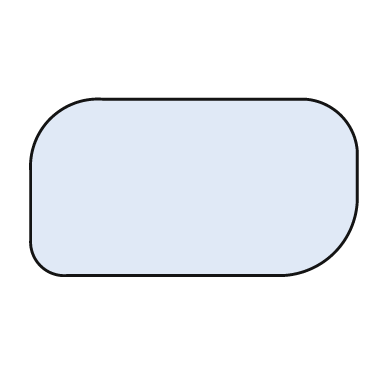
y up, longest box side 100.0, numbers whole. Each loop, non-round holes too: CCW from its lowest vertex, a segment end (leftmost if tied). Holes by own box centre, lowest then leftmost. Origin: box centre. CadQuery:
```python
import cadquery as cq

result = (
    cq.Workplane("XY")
    .moveTo(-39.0, -27.0)
    .lineTo(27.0, -27.0)
    .threePointArc((43.0, -20.0), (50.0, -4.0))
    .lineTo(50.0, 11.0)
    .threePointArc((45.0, 22.0), (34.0, 27.0))
    .lineTo(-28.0, 27.0)
    .threePointArc((-44.0, 21.0), (-50.0, 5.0))
    .lineTo(-50.0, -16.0)
    .threePointArc((-47.0, -24.0), (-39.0, -27.0))
    .close()
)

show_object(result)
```